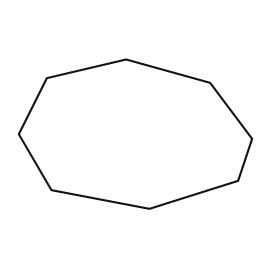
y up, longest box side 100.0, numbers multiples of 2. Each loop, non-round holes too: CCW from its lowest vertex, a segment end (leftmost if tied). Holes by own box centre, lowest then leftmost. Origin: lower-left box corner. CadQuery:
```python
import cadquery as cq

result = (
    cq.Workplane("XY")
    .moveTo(56.0, 0.0)
    .lineTo(94.0, 12.0)
    .lineTo(100.0, 30.0)
    .lineTo(82.0, 54.0)
    .lineTo(46.0, 64.0)
    .lineTo(12.0, 56.0)
    .lineTo(0.0, 32.0)
    .lineTo(14.0, 8.0)
    .close()
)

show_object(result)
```